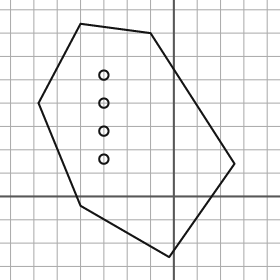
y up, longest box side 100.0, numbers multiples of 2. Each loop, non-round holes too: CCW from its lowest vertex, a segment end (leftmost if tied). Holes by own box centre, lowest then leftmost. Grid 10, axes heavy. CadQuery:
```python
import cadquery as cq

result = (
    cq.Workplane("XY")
    .moveTo(-2.0, -26.0)
    .lineTo(26.0, 14.0)
    .lineTo(-10.0, 70.0)
    .lineTo(-40.0, 74.0)
    .lineTo(-58.0, 40.0)
    .lineTo(-40.0, -4.0)
    .close()
    .moveTo(-30.0, 16.0)
    .circle(2.0)
    .moveTo(-30.0, 28.0)
    .circle(2.0)
    .moveTo(-30.0, 40.0)
    .circle(2.0)
    .moveTo(-30.0, 52.0)
    .circle(2.0)
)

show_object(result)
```